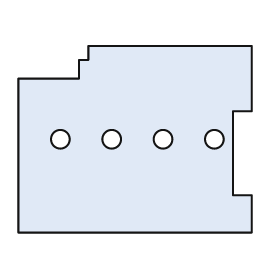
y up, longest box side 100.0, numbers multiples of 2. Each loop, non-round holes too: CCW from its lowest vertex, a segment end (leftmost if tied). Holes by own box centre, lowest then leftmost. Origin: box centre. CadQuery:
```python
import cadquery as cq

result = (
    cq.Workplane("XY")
    .moveTo(-50.0, -40.0)
    .lineTo(50.0, -40.0)
    .lineTo(50.0, -24.0)
    .lineTo(42.0, -24.0)
    .lineTo(42.0, 12.0)
    .lineTo(50.0, 12.0)
    .lineTo(50.0, 40.0)
    .lineTo(-20.0, 40.0)
    .lineTo(-20.0, 34.0)
    .lineTo(-24.0, 34.0)
    .lineTo(-24.0, 26.0)
    .lineTo(-50.0, 26.0)
    .close()
    .moveTo(-32.0, 0.0)
    .circle(4.0)
    .moveTo(-10.0, 0.0)
    .circle(4.0)
    .moveTo(12.0, 0.0)
    .circle(4.0)
    .moveTo(34.0, 0.0)
    .circle(4.0)
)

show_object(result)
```